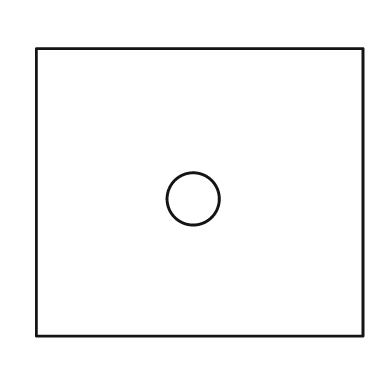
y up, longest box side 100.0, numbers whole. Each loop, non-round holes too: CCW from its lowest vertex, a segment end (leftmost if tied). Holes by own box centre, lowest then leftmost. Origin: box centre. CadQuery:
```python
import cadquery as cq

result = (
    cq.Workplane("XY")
    .moveTo(-50.0, -44.0)
    .lineTo(50.0, -44.0)
    .lineTo(50.0, 44.0)
    .lineTo(-50.0, 44.0)
    .close()
    .moveTo(-2.0, -2.0)
    .circle(8.0)
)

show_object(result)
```